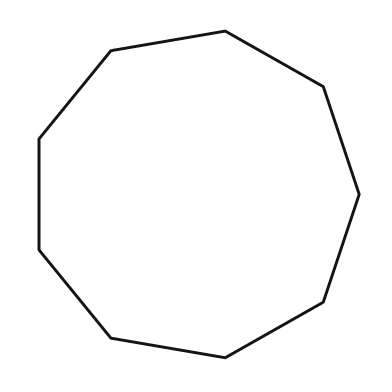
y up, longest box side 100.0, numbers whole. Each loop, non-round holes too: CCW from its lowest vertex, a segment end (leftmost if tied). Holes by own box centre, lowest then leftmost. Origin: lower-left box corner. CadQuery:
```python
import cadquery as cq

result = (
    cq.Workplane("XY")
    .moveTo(57.0, 0.0)
    .lineTo(87.0, 17.0)
    .lineTo(98.0, 50.0)
    .lineTo(87.0, 83.0)
    .lineTo(57.0, 100.0)
    .lineTo(22.0, 94.0)
    .lineTo(0.0, 67.0)
    .lineTo(0.0, 33.0)
    .lineTo(22.0, 6.0)
    .close()
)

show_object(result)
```